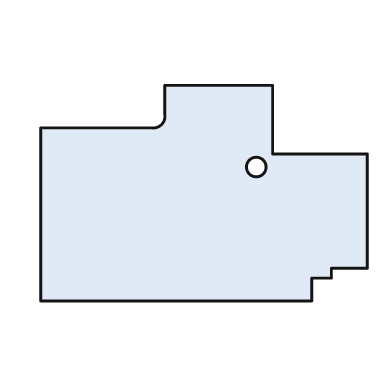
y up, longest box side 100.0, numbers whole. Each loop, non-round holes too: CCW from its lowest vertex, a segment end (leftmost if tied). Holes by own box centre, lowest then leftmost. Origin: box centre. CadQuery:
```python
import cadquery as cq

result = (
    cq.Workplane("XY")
    .moveTo(-50.0, -33.0)
    .lineTo(33.0, -33.0)
    .lineTo(33.0, -26.0)
    .lineTo(39.0, -26.0)
    .lineTo(39.0, -23.0)
    .lineTo(50.0, -23.0)
    .lineTo(50.0, 12.0)
    .lineTo(21.0, 12.0)
    .lineTo(21.0, 33.0)
    .lineTo(-12.0, 33.0)
    .lineTo(-12.0, 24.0)
    .threePointArc((-13.0, 21.0), (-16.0, 20.0))
    .lineTo(-50.0, 20.0)
    .close()
    .moveTo(16.0, 8.0)
    .circle(3.0)
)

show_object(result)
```